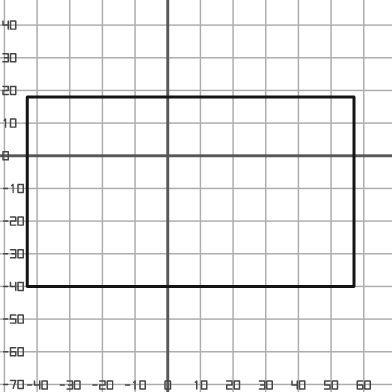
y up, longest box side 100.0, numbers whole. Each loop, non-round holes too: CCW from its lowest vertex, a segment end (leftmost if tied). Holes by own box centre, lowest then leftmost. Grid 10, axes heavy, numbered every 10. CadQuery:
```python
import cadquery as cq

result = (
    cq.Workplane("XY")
    .moveTo(-43.0, -40.0)
    .lineTo(57.0, -40.0)
    .lineTo(57.0, 18.0)
    .lineTo(-43.0, 18.0)
    .close()
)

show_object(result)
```